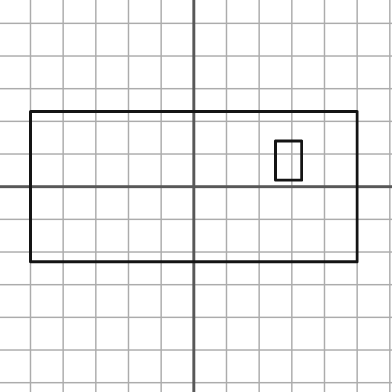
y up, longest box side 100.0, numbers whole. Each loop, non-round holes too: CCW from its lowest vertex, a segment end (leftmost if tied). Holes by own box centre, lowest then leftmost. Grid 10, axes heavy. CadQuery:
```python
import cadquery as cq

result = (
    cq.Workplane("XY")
    .moveTo(-50.0, -23.0)
    .lineTo(50.0, -23.0)
    .lineTo(50.0, 23.0)
    .lineTo(-50.0, 23.0)
    .close()
    .moveTo(25.0, 2.0)
    .lineTo(33.0, 2.0)
    .lineTo(33.0, 14.0)
    .lineTo(25.0, 14.0)
    .close()
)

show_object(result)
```